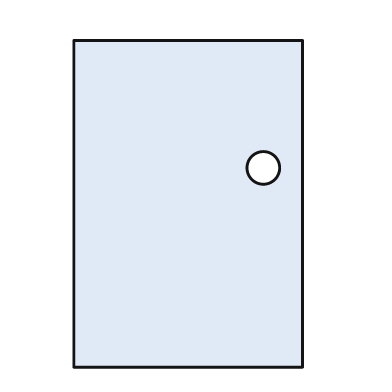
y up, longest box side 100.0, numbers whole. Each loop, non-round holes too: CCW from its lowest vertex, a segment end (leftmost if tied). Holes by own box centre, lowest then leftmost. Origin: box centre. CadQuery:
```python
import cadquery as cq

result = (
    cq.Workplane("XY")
    .moveTo(-35.0, -50.0)
    .lineTo(35.0, -50.0)
    .lineTo(35.0, 50.0)
    .lineTo(-35.0, 50.0)
    .close()
    .moveTo(23.0, 11.0)
    .circle(5.0)
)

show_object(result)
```